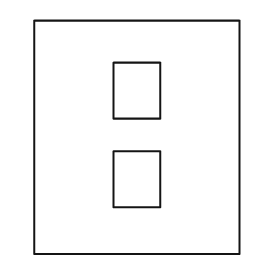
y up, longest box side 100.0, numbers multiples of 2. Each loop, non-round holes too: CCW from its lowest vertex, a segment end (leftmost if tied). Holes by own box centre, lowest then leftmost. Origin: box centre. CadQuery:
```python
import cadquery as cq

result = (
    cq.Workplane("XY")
    .moveTo(-44.0, -50.0)
    .lineTo(44.0, -50.0)
    .lineTo(44.0, 50.0)
    .lineTo(-44.0, 50.0)
    .close()
    .moveTo(-10.0, -30.0)
    .lineTo(10.0, -30.0)
    .lineTo(10.0, -6.0)
    .lineTo(-10.0, -6.0)
    .close()
    .moveTo(-10.0, 8.0)
    .lineTo(10.0, 8.0)
    .lineTo(10.0, 32.0)
    .lineTo(-10.0, 32.0)
    .close()
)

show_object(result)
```